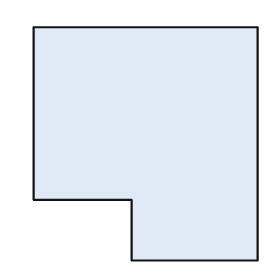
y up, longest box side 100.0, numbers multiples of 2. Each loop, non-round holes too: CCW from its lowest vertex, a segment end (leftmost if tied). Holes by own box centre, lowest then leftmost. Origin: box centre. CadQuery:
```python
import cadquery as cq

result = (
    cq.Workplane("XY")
    .moveTo(-6.0, -50.0)
    .lineTo(48.0, -50.0)
    .lineTo(48.0, 50.0)
    .lineTo(-48.0, 50.0)
    .lineTo(-48.0, -24.0)
    .lineTo(-6.0, -24.0)
    .close()
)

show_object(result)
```